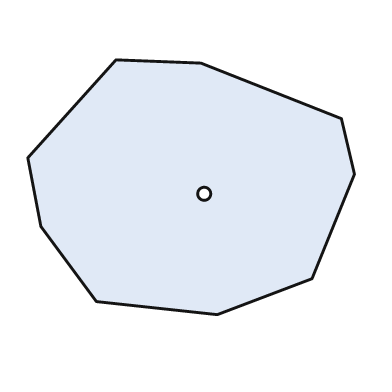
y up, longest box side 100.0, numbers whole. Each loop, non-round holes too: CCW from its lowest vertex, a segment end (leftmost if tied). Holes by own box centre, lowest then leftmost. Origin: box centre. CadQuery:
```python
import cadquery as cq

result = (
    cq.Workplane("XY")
    .moveTo(8.0, -39.0)
    .lineTo(37.0, -28.0)
    .lineTo(50.0, 4.0)
    .lineTo(46.0, 21.0)
    .lineTo(3.0, 38.0)
    .lineTo(-23.0, 39.0)
    .lineTo(-50.0, 9.0)
    .lineTo(-46.0, -12.0)
    .lineTo(-29.0, -35.0)
    .close()
    .moveTo(4.0, -2.0)
    .circle(2.0)
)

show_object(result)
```